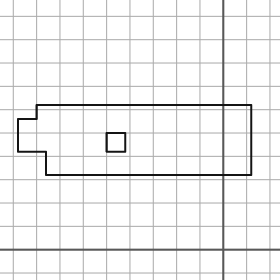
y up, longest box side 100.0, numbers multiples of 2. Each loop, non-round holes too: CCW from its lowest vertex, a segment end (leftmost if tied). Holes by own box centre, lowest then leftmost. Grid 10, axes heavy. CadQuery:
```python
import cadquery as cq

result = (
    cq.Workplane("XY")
    .moveTo(-76.0, 32.0)
    .lineTo(12.0, 32.0)
    .lineTo(12.0, 62.0)
    .lineTo(-80.0, 62.0)
    .lineTo(-80.0, 56.0)
    .lineTo(-88.0, 56.0)
    .lineTo(-88.0, 42.0)
    .lineTo(-76.0, 42.0)
    .close()
    .moveTo(-50.0, 42.0)
    .lineTo(-42.0, 42.0)
    .lineTo(-42.0, 50.0)
    .lineTo(-50.0, 50.0)
    .close()
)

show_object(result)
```